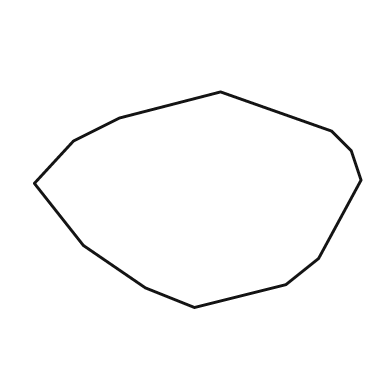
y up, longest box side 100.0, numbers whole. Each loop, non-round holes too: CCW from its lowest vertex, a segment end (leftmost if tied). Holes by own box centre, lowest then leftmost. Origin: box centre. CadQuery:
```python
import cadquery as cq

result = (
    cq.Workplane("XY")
    .moveTo(-1.0, -33.0)
    .lineTo(27.0, -26.0)
    .lineTo(37.0, -18.0)
    .lineTo(50.0, 6.0)
    .lineTo(47.0, 15.0)
    .lineTo(41.0, 21.0)
    .lineTo(7.0, 33.0)
    .lineTo(-24.0, 25.0)
    .lineTo(-38.0, 18.0)
    .lineTo(-50.0, 5.0)
    .lineTo(-35.0, -14.0)
    .lineTo(-16.0, -27.0)
    .close()
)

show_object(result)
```